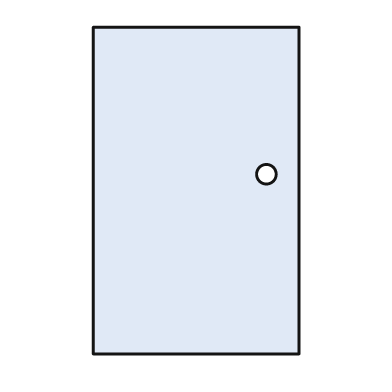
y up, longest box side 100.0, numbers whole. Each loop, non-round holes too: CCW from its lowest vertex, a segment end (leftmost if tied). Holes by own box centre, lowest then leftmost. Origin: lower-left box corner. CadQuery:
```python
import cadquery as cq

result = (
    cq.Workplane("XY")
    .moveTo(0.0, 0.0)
    .lineTo(63.0, 0.0)
    .lineTo(63.0, 100.0)
    .lineTo(0.0, 100.0)
    .close()
    .moveTo(53.0, 55.0)
    .circle(3.0)
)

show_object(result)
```